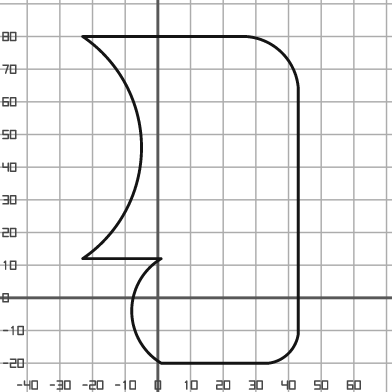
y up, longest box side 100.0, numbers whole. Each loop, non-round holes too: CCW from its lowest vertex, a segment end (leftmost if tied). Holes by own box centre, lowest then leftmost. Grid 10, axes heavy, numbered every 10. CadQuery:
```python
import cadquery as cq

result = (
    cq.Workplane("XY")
    .moveTo(1.0, -20.0)
    .lineTo(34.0, -20.0)
    .threePointArc((40.0, -17.0), (43.0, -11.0))
    .lineTo(43.0, 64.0)
    .threePointArc((38.0, 75.0), (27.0, 80.0))
    .lineTo(-23.0, 80.0)
    .threePointArc((-5.0, 46.0), (-23.0, 12.0))
    .lineTo(1.0, 12.0)
    .threePointArc((-8.0, -4.0), (1.0, -20.0))
    .close()
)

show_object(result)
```